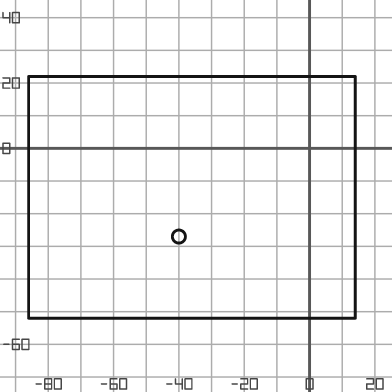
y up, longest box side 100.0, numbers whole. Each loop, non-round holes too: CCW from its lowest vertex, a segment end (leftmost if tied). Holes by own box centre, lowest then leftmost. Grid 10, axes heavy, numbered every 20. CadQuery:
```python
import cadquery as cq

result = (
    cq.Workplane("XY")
    .moveTo(-86.0, -52.0)
    .lineTo(14.0, -52.0)
    .lineTo(14.0, 22.0)
    .lineTo(-86.0, 22.0)
    .close()
    .moveTo(-40.0, -27.0)
    .circle(2.0)
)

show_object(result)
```